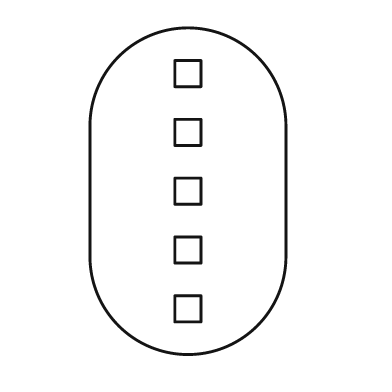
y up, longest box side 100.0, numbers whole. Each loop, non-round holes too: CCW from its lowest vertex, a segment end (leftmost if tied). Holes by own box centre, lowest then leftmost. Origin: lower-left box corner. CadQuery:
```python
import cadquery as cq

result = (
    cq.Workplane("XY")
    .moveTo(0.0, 30.0)
    .threePointArc((30.0, 0.0), (60.0, 30.0))
    .lineTo(60.0, 70.0)
    .threePointArc((30.0, 100.0), (0.0, 70.0))
    .close()
    .moveTo(26.0, 10.0)
    .lineTo(34.0, 10.0)
    .lineTo(34.0, 18.0)
    .lineTo(26.0, 18.0)
    .close()
    .moveTo(26.0, 28.0)
    .lineTo(34.0, 28.0)
    .lineTo(34.0, 36.0)
    .lineTo(26.0, 36.0)
    .close()
    .moveTo(26.0, 46.0)
    .lineTo(34.0, 46.0)
    .lineTo(34.0, 54.0)
    .lineTo(26.0, 54.0)
    .close()
    .moveTo(26.0, 64.0)
    .lineTo(34.0, 64.0)
    .lineTo(34.0, 72.0)
    .lineTo(26.0, 72.0)
    .close()
    .moveTo(26.0, 82.0)
    .lineTo(34.0, 82.0)
    .lineTo(34.0, 90.0)
    .lineTo(26.0, 90.0)
    .close()
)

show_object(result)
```